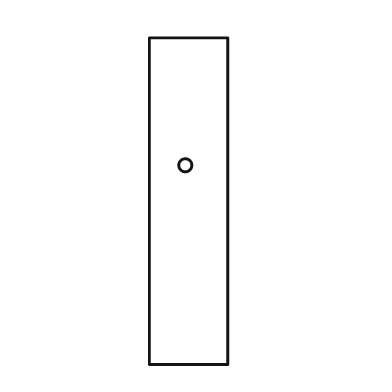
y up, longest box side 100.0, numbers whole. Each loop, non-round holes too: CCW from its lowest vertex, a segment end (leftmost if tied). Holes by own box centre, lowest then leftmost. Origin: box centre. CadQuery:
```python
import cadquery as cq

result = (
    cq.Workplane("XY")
    .moveTo(-12.0, -50.0)
    .lineTo(12.0, -50.0)
    .lineTo(12.0, 50.0)
    .lineTo(-12.0, 50.0)
    .close()
    .moveTo(-1.0, 11.0)
    .circle(2.0)
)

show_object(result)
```